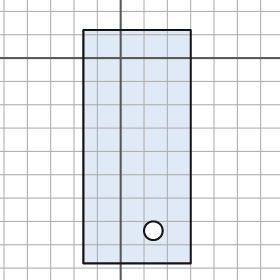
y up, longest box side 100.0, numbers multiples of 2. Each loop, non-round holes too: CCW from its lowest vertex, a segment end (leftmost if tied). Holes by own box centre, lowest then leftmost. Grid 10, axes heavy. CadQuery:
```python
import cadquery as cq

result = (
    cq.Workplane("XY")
    .moveTo(-16.0, -88.0)
    .lineTo(30.0, -88.0)
    .lineTo(30.0, 12.0)
    .lineTo(-16.0, 12.0)
    .close()
    .moveTo(14.0, -74.0)
    .circle(4.0)
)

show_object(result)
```